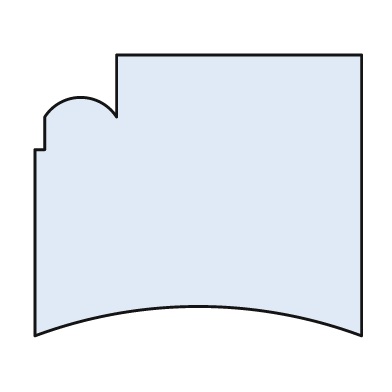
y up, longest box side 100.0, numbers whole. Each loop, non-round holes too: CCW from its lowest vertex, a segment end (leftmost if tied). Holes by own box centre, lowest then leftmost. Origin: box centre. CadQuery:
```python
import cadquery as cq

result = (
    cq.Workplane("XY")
    .moveTo(-50.0, -43.0)
    .threePointArc((0.0, -34.0), (50.0, -43.0))
    .lineTo(50.0, 43.0)
    .lineTo(-25.0, 43.0)
    .lineTo(-25.0, 24.0)
    .threePointArc((-36.0, 30.0), (-47.0, 24.0))
    .lineTo(-47.0, 14.0)
    .lineTo(-50.0, 14.0)
    .close()
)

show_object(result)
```